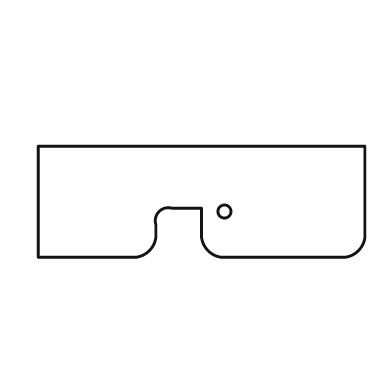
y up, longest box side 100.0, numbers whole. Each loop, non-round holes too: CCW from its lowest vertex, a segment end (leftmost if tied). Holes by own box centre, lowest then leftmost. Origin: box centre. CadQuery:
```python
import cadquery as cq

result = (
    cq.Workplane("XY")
    .moveTo(-50.0, -17.0)
    .lineTo(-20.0, -17.0)
    .threePointArc((-16.0, -15.0), (-14.0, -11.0))
    .lineTo(-14.0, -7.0)
    .threePointArc((-13.0, -3.0), (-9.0, -2.0))
    .lineTo(0.0, -2.0)
    .lineTo(0.0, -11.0)
    .threePointArc((2.0, -15.0), (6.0, -17.0))
    .lineTo(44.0, -17.0)
    .threePointArc((48.0, -15.0), (50.0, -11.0))
    .lineTo(50.0, 17.0)
    .lineTo(-50.0, 17.0)
    .close()
    .moveTo(7.0, -3.0)
    .circle(2.0)
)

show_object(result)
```